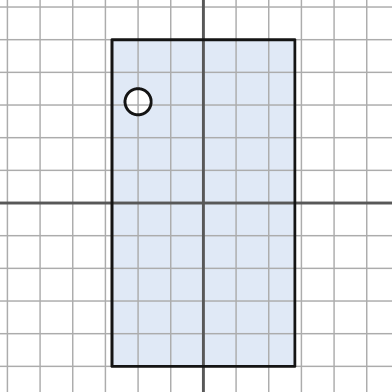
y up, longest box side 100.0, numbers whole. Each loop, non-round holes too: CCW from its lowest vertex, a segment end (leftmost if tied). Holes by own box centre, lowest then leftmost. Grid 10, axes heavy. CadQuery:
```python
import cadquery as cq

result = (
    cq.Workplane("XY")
    .moveTo(-28.0, -50.0)
    .lineTo(28.0, -50.0)
    .lineTo(28.0, 50.0)
    .lineTo(-28.0, 50.0)
    .close()
    .moveTo(-20.0, 31.0)
    .circle(4.0)
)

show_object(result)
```